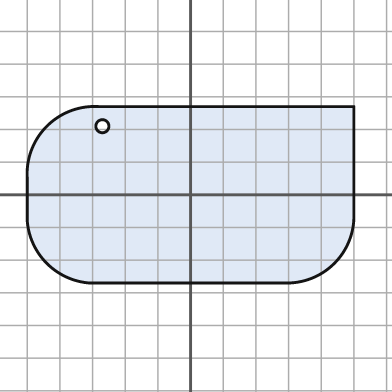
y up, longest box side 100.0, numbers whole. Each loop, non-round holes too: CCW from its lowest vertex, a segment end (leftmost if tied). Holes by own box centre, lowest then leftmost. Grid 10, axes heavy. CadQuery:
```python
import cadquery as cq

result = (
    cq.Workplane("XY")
    .moveTo(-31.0, -27.0)
    .lineTo(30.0, -27.0)
    .threePointArc((44.0, -21.0), (50.0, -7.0))
    .lineTo(50.0, 27.0)
    .lineTo(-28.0, 27.0)
    .threePointArc((-44.0, 21.0), (-50.0, 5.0))
    .lineTo(-50.0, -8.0)
    .threePointArc((-44.0, -21.0), (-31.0, -27.0))
    .close()
    .moveTo(-27.0, 21.0)
    .circle(2.0)
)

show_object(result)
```